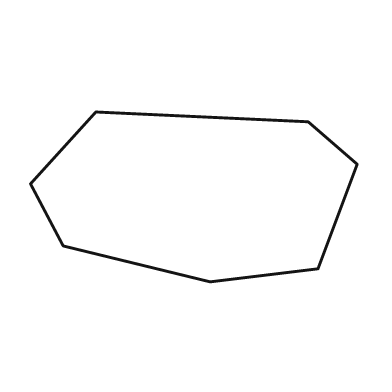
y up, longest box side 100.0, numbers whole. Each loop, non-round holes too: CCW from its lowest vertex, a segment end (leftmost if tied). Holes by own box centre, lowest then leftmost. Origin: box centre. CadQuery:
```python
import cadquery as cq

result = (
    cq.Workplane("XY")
    .moveTo(5.0, -26.0)
    .lineTo(38.0, -22.0)
    .lineTo(50.0, 10.0)
    .lineTo(35.0, 23.0)
    .lineTo(-30.0, 26.0)
    .lineTo(-50.0, 4.0)
    .lineTo(-40.0, -15.0)
    .close()
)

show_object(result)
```